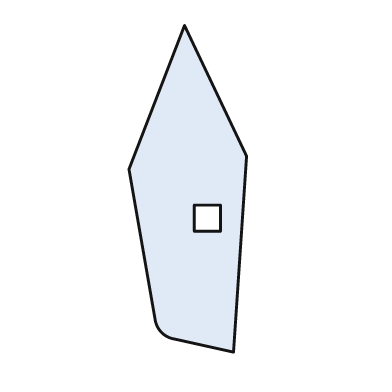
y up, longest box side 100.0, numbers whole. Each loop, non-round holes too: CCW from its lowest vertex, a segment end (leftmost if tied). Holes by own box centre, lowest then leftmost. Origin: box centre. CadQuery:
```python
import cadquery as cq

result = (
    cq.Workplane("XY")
    .moveTo(14.0, -50.0)
    .lineTo(18.0, 10.0)
    .lineTo(-1.0, 50.0)
    .lineTo(-18.0, 6.0)
    .lineTo(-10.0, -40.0)
    .threePointArc((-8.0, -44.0), (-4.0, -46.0))
    .close()
    .moveTo(2.0, -13.0)
    .lineTo(10.0, -13.0)
    .lineTo(10.0, -5.0)
    .lineTo(2.0, -5.0)
    .close()
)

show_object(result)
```